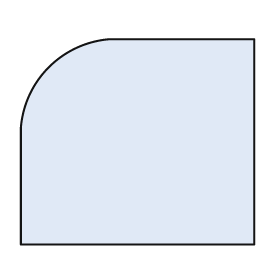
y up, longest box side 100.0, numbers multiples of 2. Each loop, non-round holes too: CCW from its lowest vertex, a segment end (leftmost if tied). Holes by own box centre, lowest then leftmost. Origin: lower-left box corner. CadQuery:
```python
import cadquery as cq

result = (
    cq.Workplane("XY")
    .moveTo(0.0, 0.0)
    .lineTo(100.0, 0.0)
    .lineTo(100.0, 88.0)
    .lineTo(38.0, 88.0)
    .threePointArc((12.0, 76.0), (0.0, 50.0))
    .close()
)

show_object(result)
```